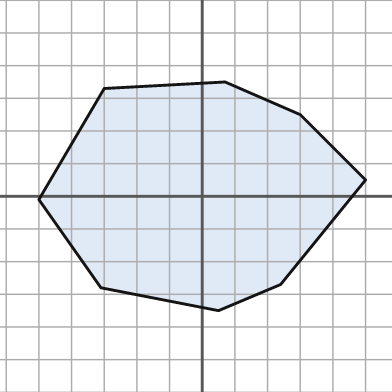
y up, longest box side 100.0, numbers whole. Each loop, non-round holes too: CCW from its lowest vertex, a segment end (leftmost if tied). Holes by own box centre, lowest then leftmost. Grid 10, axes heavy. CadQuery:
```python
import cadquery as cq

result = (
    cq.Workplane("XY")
    .moveTo(5.0, -35.0)
    .lineTo(24.0, -27.0)
    .lineTo(50.0, 5.0)
    .lineTo(30.0, 25.0)
    .lineTo(7.0, 35.0)
    .lineTo(-30.0, 33.0)
    .lineTo(-50.0, -1.0)
    .lineTo(-31.0, -28.0)
    .close()
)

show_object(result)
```